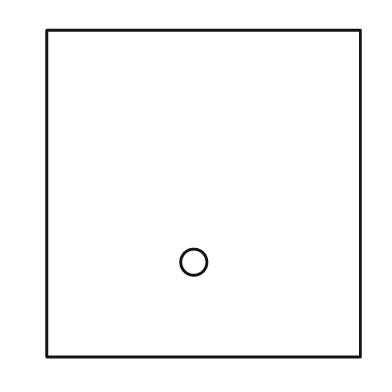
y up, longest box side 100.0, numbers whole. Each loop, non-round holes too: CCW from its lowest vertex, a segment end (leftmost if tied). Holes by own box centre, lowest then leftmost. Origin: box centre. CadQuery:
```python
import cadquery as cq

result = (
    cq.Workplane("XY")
    .moveTo(-48.0, -50.0)
    .lineTo(48.0, -50.0)
    .lineTo(48.0, 50.0)
    .lineTo(-48.0, 50.0)
    .close()
    .moveTo(-3.0, -21.0)
    .circle(4.0)
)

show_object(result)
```